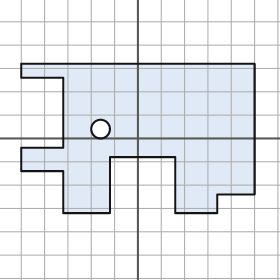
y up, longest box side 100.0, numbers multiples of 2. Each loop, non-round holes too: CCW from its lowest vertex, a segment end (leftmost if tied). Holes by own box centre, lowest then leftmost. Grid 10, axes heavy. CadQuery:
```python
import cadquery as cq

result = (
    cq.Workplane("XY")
    .moveTo(-32.0, -32.0)
    .lineTo(-12.0, -32.0)
    .lineTo(-12.0, -8.0)
    .lineTo(16.0, -8.0)
    .lineTo(16.0, -32.0)
    .lineTo(34.0, -32.0)
    .lineTo(34.0, -24.0)
    .lineTo(50.0, -24.0)
    .lineTo(50.0, 32.0)
    .lineTo(-50.0, 32.0)
    .lineTo(-50.0, 26.0)
    .lineTo(-32.0, 26.0)
    .lineTo(-32.0, -4.0)
    .lineTo(-50.0, -4.0)
    .lineTo(-50.0, -14.0)
    .lineTo(-32.0, -14.0)
    .close()
    .moveTo(-16.0, 4.0)
    .circle(4.0)
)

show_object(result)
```